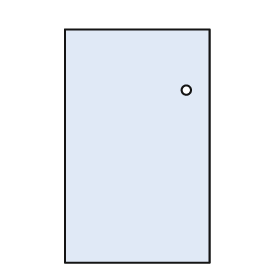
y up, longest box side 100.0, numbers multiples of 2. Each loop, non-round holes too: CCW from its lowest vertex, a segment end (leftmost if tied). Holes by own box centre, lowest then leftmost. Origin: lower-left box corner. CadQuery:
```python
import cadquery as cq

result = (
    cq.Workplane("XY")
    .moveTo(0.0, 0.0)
    .lineTo(62.0, 0.0)
    .lineTo(62.0, 100.0)
    .lineTo(0.0, 100.0)
    .close()
    .moveTo(52.0, 74.0)
    .circle(2.0)
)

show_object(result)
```